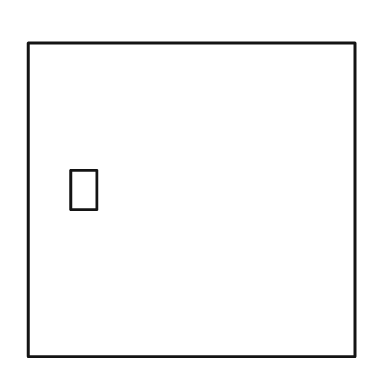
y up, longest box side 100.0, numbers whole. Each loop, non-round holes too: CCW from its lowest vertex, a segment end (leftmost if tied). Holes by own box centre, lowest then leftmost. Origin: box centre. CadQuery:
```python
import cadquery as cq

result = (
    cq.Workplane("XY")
    .moveTo(-50.0, -48.0)
    .lineTo(50.0, -48.0)
    .lineTo(50.0, 48.0)
    .lineTo(-50.0, 48.0)
    .close()
    .moveTo(-37.0, -3.0)
    .lineTo(-29.0, -3.0)
    .lineTo(-29.0, 9.0)
    .lineTo(-37.0, 9.0)
    .close()
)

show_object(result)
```